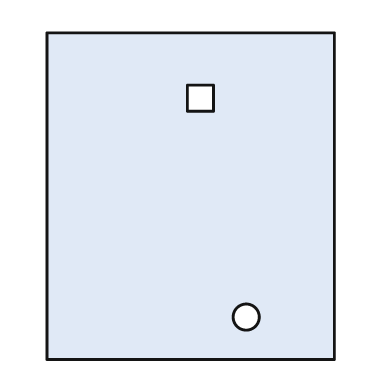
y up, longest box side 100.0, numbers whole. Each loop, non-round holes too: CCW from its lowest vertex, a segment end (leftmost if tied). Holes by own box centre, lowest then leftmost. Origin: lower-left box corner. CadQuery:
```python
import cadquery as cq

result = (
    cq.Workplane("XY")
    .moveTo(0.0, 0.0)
    .lineTo(88.0, 0.0)
    .lineTo(88.0, 100.0)
    .lineTo(0.0, 100.0)
    .close()
    .moveTo(61.0, 13.0)
    .circle(4.0)
    .moveTo(43.0, 76.0)
    .lineTo(51.0, 76.0)
    .lineTo(51.0, 84.0)
    .lineTo(43.0, 84.0)
    .close()
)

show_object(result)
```